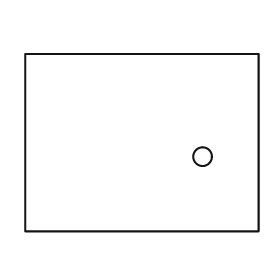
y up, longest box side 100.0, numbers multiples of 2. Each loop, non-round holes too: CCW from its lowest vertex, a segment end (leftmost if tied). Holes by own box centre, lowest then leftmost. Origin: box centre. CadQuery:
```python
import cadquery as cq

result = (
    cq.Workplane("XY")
    .moveTo(-50.0, -38.0)
    .lineTo(50.0, -38.0)
    .lineTo(50.0, 38.0)
    .lineTo(-50.0, 38.0)
    .close()
    .moveTo(26.0, -6.0)
    .circle(4.0)
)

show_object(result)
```